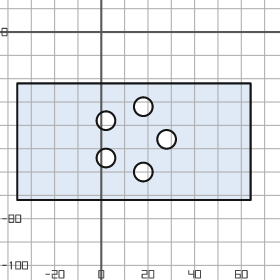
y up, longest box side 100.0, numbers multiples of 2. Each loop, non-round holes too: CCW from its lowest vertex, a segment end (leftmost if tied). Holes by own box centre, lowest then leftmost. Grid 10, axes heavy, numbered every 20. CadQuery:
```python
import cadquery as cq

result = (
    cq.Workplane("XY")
    .moveTo(-36.0, -72.0)
    .lineTo(64.0, -72.0)
    .lineTo(64.0, -22.0)
    .lineTo(-36.0, -22.0)
    .close()
    .moveTo(18.0, -60.0)
    .circle(4.0)
    .moveTo(2.0, -54.0)
    .circle(4.0)
    .moveTo(28.0, -46.0)
    .circle(4.0)
    .moveTo(2.0, -38.0)
    .circle(4.0)
    .moveTo(18.0, -32.0)
    .circle(4.0)
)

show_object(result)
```